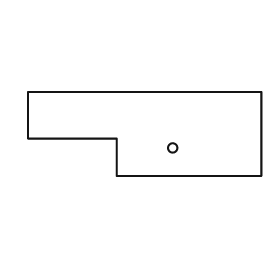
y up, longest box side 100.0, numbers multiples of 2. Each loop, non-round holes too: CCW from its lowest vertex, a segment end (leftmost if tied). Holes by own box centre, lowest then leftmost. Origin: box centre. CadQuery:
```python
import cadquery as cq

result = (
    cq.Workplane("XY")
    .moveTo(-12.0, -18.0)
    .lineTo(50.0, -18.0)
    .lineTo(50.0, 18.0)
    .lineTo(-50.0, 18.0)
    .lineTo(-50.0, -2.0)
    .lineTo(-12.0, -2.0)
    .close()
    .moveTo(12.0, -6.0)
    .circle(2.0)
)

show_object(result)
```